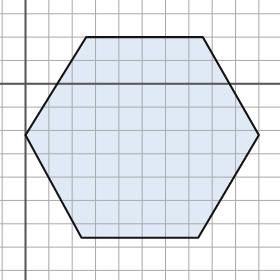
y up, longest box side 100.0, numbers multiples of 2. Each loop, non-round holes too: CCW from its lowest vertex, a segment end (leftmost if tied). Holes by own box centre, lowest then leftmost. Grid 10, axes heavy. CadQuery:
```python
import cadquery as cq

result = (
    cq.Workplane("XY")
    .moveTo(24.0, -66.0)
    .lineTo(74.0, -66.0)
    .lineTo(100.0, -22.0)
    .lineTo(76.0, 20.0)
    .lineTo(26.0, 20.0)
    .lineTo(0.0, -22.0)
    .close()
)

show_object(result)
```